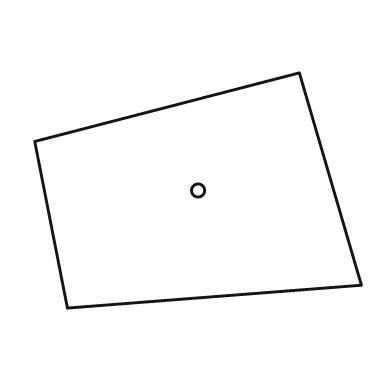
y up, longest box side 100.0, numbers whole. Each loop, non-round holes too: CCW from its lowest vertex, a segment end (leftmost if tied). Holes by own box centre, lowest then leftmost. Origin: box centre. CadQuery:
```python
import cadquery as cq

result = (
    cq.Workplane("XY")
    .moveTo(-40.0, -36.0)
    .lineTo(50.0, -29.0)
    .lineTo(31.0, 36.0)
    .lineTo(-50.0, 15.0)
    .close()
    .moveTo(0.0, 0.0)
    .circle(2.0)
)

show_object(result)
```